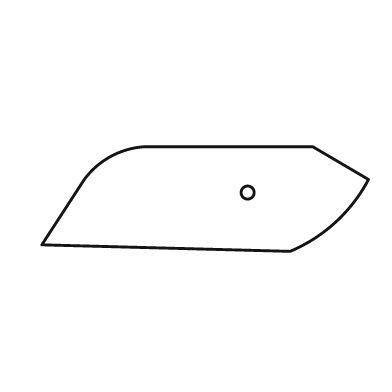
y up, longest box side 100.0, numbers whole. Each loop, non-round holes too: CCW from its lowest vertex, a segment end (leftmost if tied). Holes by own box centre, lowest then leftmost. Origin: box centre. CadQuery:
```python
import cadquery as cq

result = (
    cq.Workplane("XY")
    .moveTo(26.0, -16.0)
    .threePointArc((40.0, -7.0), (50.0, 6.0))
    .lineTo(33.0, 16.0)
    .lineTo(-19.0, 16.0)
    .threePointArc((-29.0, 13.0), (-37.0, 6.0))
    .lineTo(-50.0, -14.0)
    .close()
    .moveTo(13.0, 2.0)
    .circle(2.0)
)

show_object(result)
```